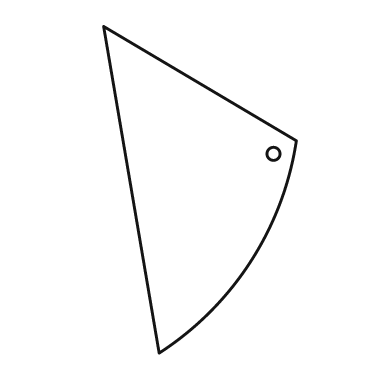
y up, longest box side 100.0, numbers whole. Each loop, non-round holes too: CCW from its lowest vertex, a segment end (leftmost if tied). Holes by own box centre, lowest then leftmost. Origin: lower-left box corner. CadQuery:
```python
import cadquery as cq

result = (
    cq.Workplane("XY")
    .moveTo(17.0, 0.0)
    .threePointArc((45.0, 28.0), (59.0, 65.0))
    .lineTo(0.0, 100.0)
    .close()
    .moveTo(52.0, 61.0)
    .circle(2.0)
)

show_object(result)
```